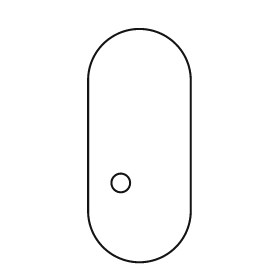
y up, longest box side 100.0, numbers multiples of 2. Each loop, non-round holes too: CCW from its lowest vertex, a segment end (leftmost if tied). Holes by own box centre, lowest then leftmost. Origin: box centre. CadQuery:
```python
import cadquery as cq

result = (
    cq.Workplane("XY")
    .moveTo(-22.0, -28.0)
    .threePointArc((0.0, -50.0), (22.0, -28.0))
    .lineTo(22.0, 28.0)
    .threePointArc((0.0, 50.0), (-22.0, 28.0))
    .close()
    .moveTo(-8.0, -16.0)
    .circle(4.0)
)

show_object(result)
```